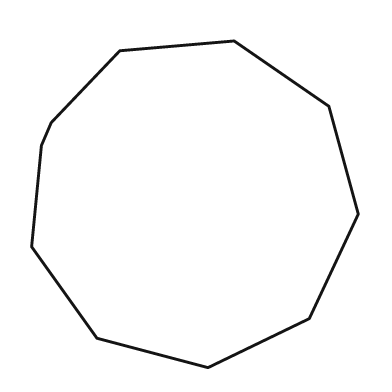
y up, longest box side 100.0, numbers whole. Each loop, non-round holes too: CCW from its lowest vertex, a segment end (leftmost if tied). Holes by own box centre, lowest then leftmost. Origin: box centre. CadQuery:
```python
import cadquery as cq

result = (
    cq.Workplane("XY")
    .moveTo(4.0, -50.0)
    .lineTo(35.0, -35.0)
    .lineTo(50.0, -3.0)
    .lineTo(41.0, 30.0)
    .lineTo(12.0, 50.0)
    .lineTo(-23.0, 47.0)
    .lineTo(-44.0, 25.0)
    .lineTo(-47.0, 18.0)
    .lineTo(-50.0, -13.0)
    .lineTo(-30.0, -41.0)
    .close()
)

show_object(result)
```